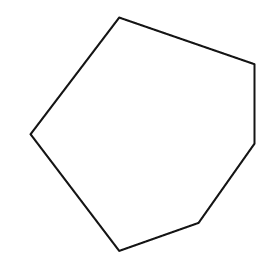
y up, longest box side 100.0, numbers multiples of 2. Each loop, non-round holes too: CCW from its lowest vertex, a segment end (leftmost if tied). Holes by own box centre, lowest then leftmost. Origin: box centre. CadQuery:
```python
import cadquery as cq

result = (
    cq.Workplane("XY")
    .moveTo(-10.0, -50.0)
    .lineTo(24.0, -38.0)
    .lineTo(48.0, -4.0)
    .lineTo(48.0, 30.0)
    .lineTo(-10.0, 50.0)
    .lineTo(-48.0, 0.0)
    .close()
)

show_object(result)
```